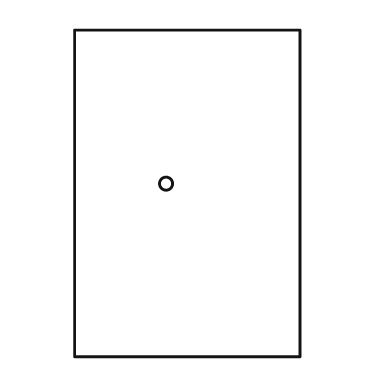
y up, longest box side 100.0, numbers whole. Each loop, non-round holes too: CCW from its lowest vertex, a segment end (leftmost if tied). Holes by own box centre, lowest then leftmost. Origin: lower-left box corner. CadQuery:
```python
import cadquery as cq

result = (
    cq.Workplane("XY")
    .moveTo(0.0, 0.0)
    .lineTo(69.0, 0.0)
    .lineTo(69.0, 100.0)
    .lineTo(0.0, 100.0)
    .close()
    .moveTo(28.0, 53.0)
    .circle(2.0)
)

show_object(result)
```